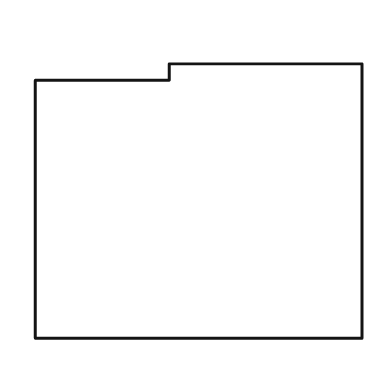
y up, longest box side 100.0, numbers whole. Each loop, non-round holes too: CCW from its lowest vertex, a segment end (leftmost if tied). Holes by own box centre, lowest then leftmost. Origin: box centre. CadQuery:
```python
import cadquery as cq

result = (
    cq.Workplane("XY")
    .moveTo(-50.0, -42.0)
    .lineTo(50.0, -42.0)
    .lineTo(50.0, 42.0)
    .lineTo(-9.0, 42.0)
    .lineTo(-9.0, 37.0)
    .lineTo(-50.0, 37.0)
    .close()
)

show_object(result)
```